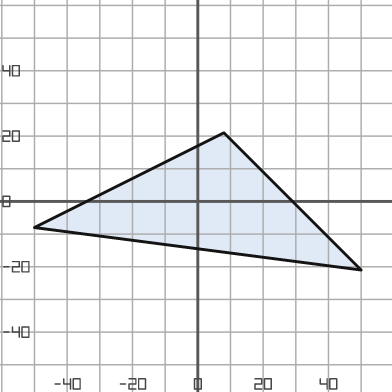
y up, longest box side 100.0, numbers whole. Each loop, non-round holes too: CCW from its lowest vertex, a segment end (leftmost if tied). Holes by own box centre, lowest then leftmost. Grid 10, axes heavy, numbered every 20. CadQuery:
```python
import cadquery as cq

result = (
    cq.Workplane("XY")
    .moveTo(50.0, -21.0)
    .lineTo(8.0, 21.0)
    .lineTo(-50.0, -8.0)
    .close()
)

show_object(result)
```